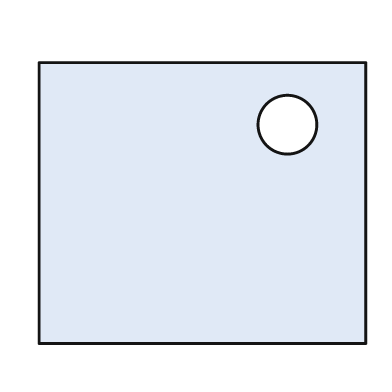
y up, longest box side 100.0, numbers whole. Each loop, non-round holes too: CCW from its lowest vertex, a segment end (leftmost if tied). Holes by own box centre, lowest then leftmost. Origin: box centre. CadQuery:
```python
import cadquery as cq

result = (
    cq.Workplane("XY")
    .moveTo(-50.0, -43.0)
    .lineTo(50.0, -43.0)
    .lineTo(50.0, 43.0)
    .lineTo(-50.0, 43.0)
    .close()
    .moveTo(26.0, 24.0)
    .circle(9.0)
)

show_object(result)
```